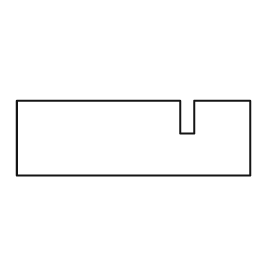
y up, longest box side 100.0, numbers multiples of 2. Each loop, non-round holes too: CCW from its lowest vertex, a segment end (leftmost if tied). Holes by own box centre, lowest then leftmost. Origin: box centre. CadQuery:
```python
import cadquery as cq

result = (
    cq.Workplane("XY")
    .moveTo(-50.0, -16.0)
    .lineTo(50.0, -16.0)
    .lineTo(50.0, 16.0)
    .lineTo(26.0, 16.0)
    .lineTo(26.0, 2.0)
    .lineTo(20.0, 2.0)
    .lineTo(20.0, 16.0)
    .lineTo(-50.0, 16.0)
    .close()
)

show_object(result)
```